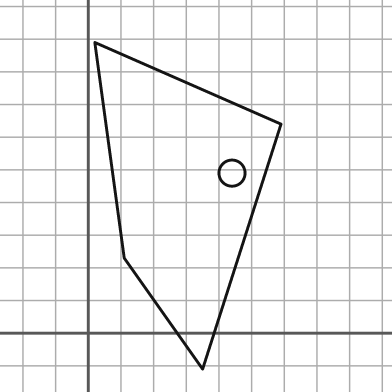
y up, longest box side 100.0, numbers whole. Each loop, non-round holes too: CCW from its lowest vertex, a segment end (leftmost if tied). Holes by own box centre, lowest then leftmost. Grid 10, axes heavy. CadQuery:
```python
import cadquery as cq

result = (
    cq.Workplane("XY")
    .moveTo(35.0, -11.0)
    .lineTo(59.0, 64.0)
    .lineTo(2.0, 89.0)
    .lineTo(11.0, 23.0)
    .close()
    .moveTo(44.0, 49.0)
    .circle(4.0)
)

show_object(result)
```